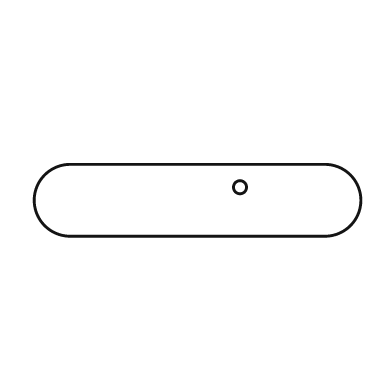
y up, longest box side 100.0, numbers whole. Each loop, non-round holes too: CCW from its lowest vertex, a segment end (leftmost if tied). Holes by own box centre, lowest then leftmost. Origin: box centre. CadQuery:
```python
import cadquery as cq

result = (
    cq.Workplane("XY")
    .moveTo(-39.0, -11.0)
    .lineTo(39.0, -11.0)
    .threePointArc((50.0, 0.0), (39.0, 11.0))
    .lineTo(-39.0, 11.0)
    .threePointArc((-50.0, 0.0), (-39.0, -11.0))
    .close()
    .moveTo(13.0, 4.0)
    .circle(2.0)
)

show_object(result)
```